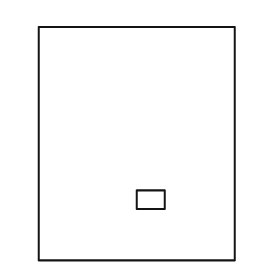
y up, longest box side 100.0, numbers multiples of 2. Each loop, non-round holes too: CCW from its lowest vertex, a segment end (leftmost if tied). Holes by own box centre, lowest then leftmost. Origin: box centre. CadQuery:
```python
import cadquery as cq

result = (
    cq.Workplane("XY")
    .moveTo(-42.0, -50.0)
    .lineTo(42.0, -50.0)
    .lineTo(42.0, 50.0)
    .lineTo(-42.0, 50.0)
    .close()
    .moveTo(0.0, -28.0)
    .lineTo(12.0, -28.0)
    .lineTo(12.0, -20.0)
    .lineTo(0.0, -20.0)
    .close()
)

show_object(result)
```